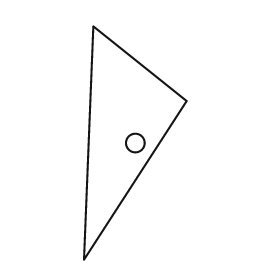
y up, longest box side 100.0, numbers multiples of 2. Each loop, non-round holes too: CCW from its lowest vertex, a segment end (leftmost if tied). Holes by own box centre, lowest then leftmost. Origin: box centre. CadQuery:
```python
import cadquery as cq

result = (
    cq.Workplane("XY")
    .moveTo(-22.0, -50.0)
    .lineTo(22.0, 18.0)
    .lineTo(-18.0, 50.0)
    .close()
    .moveTo(0.0, 0.0)
    .circle(4.0)
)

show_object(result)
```